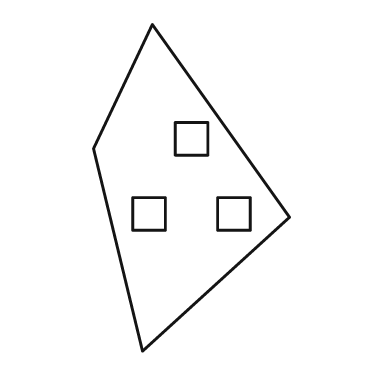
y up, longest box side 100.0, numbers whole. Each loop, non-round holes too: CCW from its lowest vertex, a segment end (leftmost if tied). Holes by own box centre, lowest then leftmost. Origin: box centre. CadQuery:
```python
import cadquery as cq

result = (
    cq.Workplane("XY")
    .moveTo(-15.0, -50.0)
    .lineTo(30.0, -9.0)
    .lineTo(-12.0, 50.0)
    .lineTo(-30.0, 12.0)
    .close()
    .moveTo(-18.0, -13.0)
    .lineTo(-8.0, -13.0)
    .lineTo(-8.0, -3.0)
    .lineTo(-18.0, -3.0)
    .close()
    .moveTo(8.0, -13.0)
    .lineTo(18.0, -13.0)
    .lineTo(18.0, -3.0)
    .lineTo(8.0, -3.0)
    .close()
    .moveTo(-5.0, 10.0)
    .lineTo(5.0, 10.0)
    .lineTo(5.0, 20.0)
    .lineTo(-5.0, 20.0)
    .close()
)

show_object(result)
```